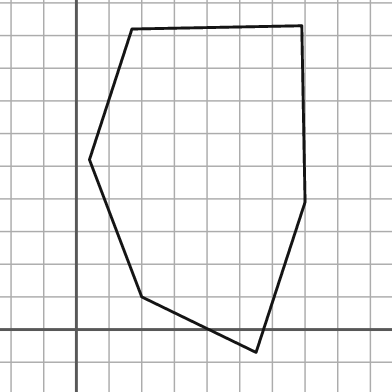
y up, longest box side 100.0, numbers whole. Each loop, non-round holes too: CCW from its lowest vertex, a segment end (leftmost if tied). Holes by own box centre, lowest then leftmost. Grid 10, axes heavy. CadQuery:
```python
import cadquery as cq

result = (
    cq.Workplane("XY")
    .moveTo(55.0, -7.0)
    .lineTo(70.0, 39.0)
    .lineTo(69.0, 93.0)
    .lineTo(17.0, 92.0)
    .lineTo(4.0, 52.0)
    .lineTo(20.0, 10.0)
    .close()
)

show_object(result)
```